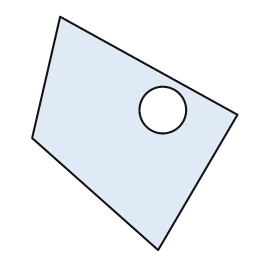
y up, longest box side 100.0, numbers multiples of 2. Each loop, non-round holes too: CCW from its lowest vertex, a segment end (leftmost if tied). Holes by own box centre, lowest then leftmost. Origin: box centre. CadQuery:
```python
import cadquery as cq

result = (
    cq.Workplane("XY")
    .moveTo(10.0, -50.0)
    .lineTo(44.0, 8.0)
    .lineTo(-32.0, 50.0)
    .lineTo(-44.0, -2.0)
    .close()
    .moveTo(12.0, 10.0)
    .circle(10.0)
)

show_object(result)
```